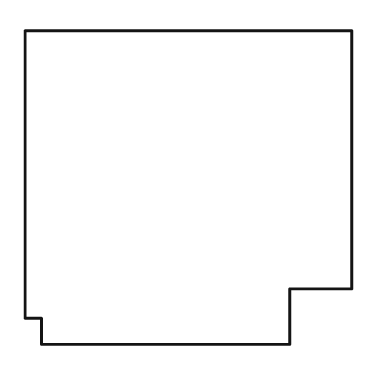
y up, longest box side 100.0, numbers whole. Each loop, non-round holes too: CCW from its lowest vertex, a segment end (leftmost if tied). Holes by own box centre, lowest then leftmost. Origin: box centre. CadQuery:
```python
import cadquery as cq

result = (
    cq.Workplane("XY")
    .moveTo(-45.0, -48.0)
    .lineTo(31.0, -48.0)
    .lineTo(31.0, -31.0)
    .lineTo(50.0, -31.0)
    .lineTo(50.0, 48.0)
    .lineTo(-50.0, 48.0)
    .lineTo(-50.0, -40.0)
    .lineTo(-45.0, -40.0)
    .close()
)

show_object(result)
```